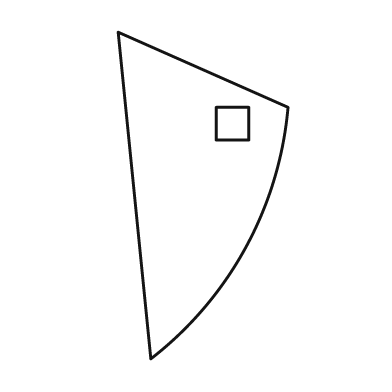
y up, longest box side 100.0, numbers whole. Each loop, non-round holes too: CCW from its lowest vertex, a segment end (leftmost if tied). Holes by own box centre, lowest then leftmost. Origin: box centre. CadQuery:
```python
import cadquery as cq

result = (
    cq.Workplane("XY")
    .moveTo(-16.0, -50.0)
    .threePointArc((13.0, -16.0), (26.0, 27.0))
    .lineTo(-26.0, 50.0)
    .close()
    .moveTo(4.0, 17.0)
    .lineTo(14.0, 17.0)
    .lineTo(14.0, 27.0)
    .lineTo(4.0, 27.0)
    .close()
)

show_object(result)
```